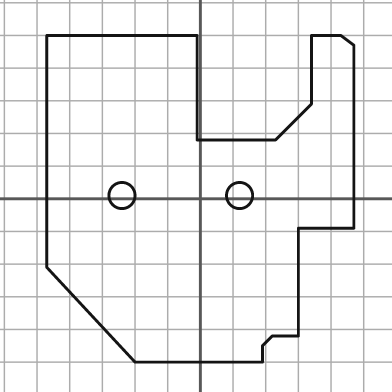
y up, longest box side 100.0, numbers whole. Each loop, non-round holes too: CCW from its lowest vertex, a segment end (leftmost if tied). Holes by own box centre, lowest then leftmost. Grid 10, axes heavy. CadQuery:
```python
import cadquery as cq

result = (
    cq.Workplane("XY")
    .moveTo(-20.0, -50.0)
    .lineTo(19.0, -50.0)
    .lineTo(19.0, -45.0)
    .lineTo(22.0, -42.0)
    .lineTo(30.0, -42.0)
    .lineTo(30.0, -9.0)
    .lineTo(47.0, -9.0)
    .lineTo(47.0, 47.0)
    .lineTo(43.0, 50.0)
    .lineTo(34.0, 50.0)
    .lineTo(34.0, 29.0)
    .lineTo(23.0, 18.0)
    .lineTo(-1.0, 18.0)
    .lineTo(-1.0, 50.0)
    .lineTo(-47.0, 50.0)
    .lineTo(-47.0, -21.0)
    .close()
    .moveTo(-24.0, 1.0)
    .circle(4.0)
    .moveTo(12.0, 1.0)
    .circle(4.0)
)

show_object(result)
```